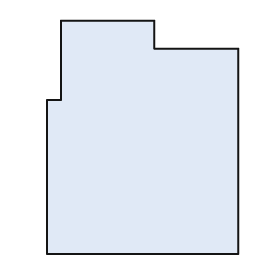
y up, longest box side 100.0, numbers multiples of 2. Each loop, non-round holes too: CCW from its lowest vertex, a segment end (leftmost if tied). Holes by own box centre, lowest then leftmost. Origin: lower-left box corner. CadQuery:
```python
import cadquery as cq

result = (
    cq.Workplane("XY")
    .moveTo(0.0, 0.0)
    .lineTo(82.0, 0.0)
    .lineTo(82.0, 88.0)
    .lineTo(46.0, 88.0)
    .lineTo(46.0, 100.0)
    .lineTo(6.0, 100.0)
    .lineTo(6.0, 66.0)
    .lineTo(0.0, 66.0)
    .close()
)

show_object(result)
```